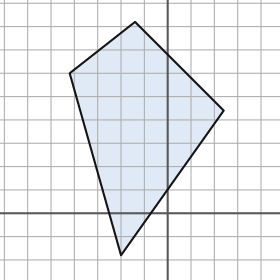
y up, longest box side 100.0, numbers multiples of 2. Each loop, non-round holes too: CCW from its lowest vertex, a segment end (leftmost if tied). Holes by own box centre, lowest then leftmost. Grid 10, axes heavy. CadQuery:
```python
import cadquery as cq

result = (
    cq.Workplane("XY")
    .moveTo(-20.0, -18.0)
    .lineTo(24.0, 44.0)
    .lineTo(-14.0, 82.0)
    .lineTo(-42.0, 60.0)
    .close()
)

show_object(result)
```